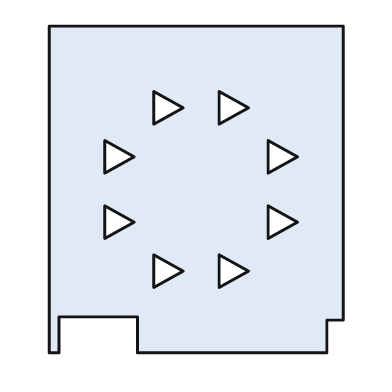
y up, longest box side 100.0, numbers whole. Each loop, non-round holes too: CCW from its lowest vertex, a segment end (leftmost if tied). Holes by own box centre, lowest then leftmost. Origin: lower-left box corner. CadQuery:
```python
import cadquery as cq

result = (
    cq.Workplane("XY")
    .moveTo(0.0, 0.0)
    .lineTo(3.0, 0.0)
    .lineTo(3.0, 11.0)
    .lineTo(27.0, 11.0)
    .lineTo(27.0, 0.0)
    .lineTo(85.0, 0.0)
    .lineTo(85.0, 10.0)
    .lineTo(90.0, 10.0)
    .lineTo(90.0, 100.0)
    .lineTo(0.0, 100.0)
    .close()
    .moveTo(32.0, 20.0)
    .lineTo(41.0, 25.0)
    .lineTo(32.0, 30.0)
    .close()
    .moveTo(52.0, 20.0)
    .lineTo(61.0, 25.0)
    .lineTo(52.0, 30.0)
    .close()
    .moveTo(17.0, 35.0)
    .lineTo(26.0, 40.0)
    .lineTo(17.0, 45.0)
    .close()
    .moveTo(67.0, 35.0)
    .lineTo(76.0, 40.0)
    .lineTo(67.0, 45.0)
    .close()
    .moveTo(17.0, 55.0)
    .lineTo(26.0, 60.0)
    .lineTo(17.0, 65.0)
    .close()
    .moveTo(67.0, 55.0)
    .lineTo(76.0, 60.0)
    .lineTo(67.0, 65.0)
    .close()
    .moveTo(32.0, 70.0)
    .lineTo(41.0, 75.0)
    .lineTo(32.0, 80.0)
    .close()
    .moveTo(52.0, 70.0)
    .lineTo(61.0, 75.0)
    .lineTo(52.0, 80.0)
    .close()
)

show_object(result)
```